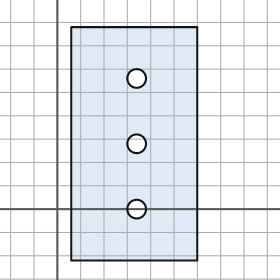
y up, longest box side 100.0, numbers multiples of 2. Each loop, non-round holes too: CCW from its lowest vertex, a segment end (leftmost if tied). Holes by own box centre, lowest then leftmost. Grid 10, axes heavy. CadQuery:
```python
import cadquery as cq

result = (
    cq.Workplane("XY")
    .moveTo(6.0, -22.0)
    .lineTo(60.0, -22.0)
    .lineTo(60.0, 78.0)
    .lineTo(6.0, 78.0)
    .close()
    .moveTo(34.0, 0.0)
    .circle(4.0)
    .moveTo(34.0, 28.0)
    .circle(4.0)
    .moveTo(34.0, 56.0)
    .circle(4.0)
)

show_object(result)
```